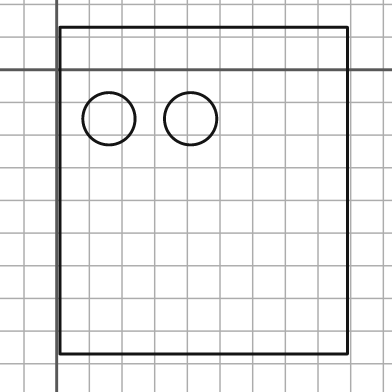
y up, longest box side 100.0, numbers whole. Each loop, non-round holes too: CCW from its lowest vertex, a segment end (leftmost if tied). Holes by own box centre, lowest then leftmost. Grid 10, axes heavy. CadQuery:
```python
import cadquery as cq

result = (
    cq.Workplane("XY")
    .moveTo(1.0, -87.0)
    .lineTo(89.0, -87.0)
    .lineTo(89.0, 13.0)
    .lineTo(1.0, 13.0)
    .close()
    .moveTo(16.0, -15.0)
    .circle(8.0)
    .moveTo(41.0, -15.0)
    .circle(8.0)
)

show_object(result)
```